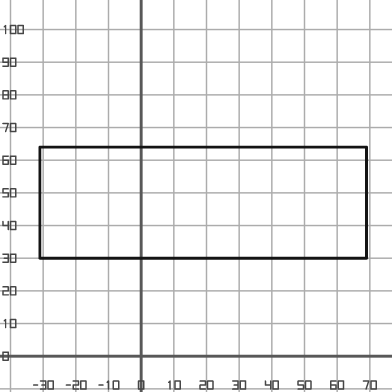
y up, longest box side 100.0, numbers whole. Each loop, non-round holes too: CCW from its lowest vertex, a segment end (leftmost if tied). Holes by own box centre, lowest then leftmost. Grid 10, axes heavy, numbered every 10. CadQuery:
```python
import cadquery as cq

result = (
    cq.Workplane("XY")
    .moveTo(-31.0, 30.0)
    .lineTo(69.0, 30.0)
    .lineTo(69.0, 64.0)
    .lineTo(-31.0, 64.0)
    .close()
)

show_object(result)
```